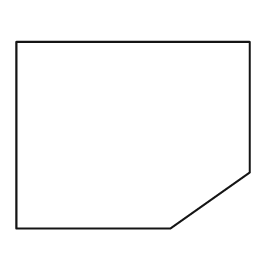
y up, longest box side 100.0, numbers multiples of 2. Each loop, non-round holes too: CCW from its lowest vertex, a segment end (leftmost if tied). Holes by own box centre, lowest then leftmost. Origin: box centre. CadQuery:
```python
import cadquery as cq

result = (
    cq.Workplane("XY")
    .moveTo(-50.0, -40.0)
    .lineTo(16.0, -40.0)
    .lineTo(50.0, -16.0)
    .lineTo(50.0, 40.0)
    .lineTo(-50.0, 40.0)
    .close()
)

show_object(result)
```